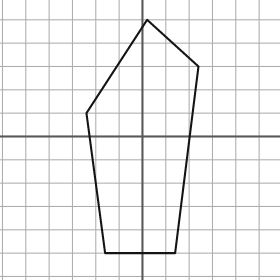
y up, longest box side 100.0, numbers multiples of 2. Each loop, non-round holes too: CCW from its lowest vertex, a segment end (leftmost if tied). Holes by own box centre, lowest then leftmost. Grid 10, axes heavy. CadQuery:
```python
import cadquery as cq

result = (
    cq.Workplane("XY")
    .moveTo(-16.0, -50.0)
    .lineTo(14.0, -50.0)
    .lineTo(24.0, 30.0)
    .lineTo(2.0, 50.0)
    .lineTo(-24.0, 10.0)
    .close()
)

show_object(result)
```